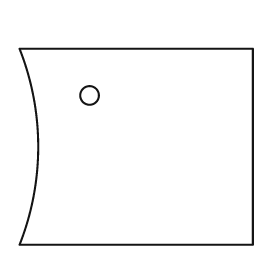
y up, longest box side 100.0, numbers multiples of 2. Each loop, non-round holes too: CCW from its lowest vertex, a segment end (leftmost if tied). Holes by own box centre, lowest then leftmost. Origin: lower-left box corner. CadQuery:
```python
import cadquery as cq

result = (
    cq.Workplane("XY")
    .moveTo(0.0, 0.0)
    .lineTo(100.0, 0.0)
    .lineTo(100.0, 84.0)
    .lineTo(0.0, 84.0)
    .threePointArc((8.0, 42.0), (0.0, 0.0))
    .close()
    .moveTo(30.0, 64.0)
    .circle(4.0)
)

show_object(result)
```